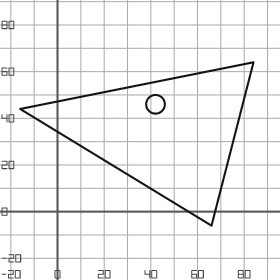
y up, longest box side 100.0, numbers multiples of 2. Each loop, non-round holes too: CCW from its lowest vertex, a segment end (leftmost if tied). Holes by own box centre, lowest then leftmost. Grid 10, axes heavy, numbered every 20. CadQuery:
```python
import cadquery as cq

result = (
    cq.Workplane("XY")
    .moveTo(66.0, -6.0)
    .lineTo(84.0, 64.0)
    .lineTo(-16.0, 44.0)
    .close()
    .moveTo(42.0, 46.0)
    .circle(4.0)
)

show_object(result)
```